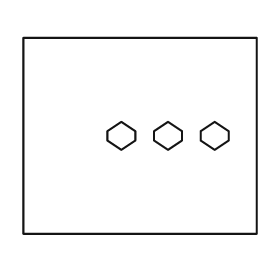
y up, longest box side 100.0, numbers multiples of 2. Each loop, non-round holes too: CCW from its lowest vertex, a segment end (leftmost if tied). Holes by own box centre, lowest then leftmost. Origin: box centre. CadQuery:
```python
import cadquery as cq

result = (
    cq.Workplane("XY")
    .moveTo(-50.0, -42.0)
    .lineTo(50.0, -42.0)
    .lineTo(50.0, 42.0)
    .lineTo(-50.0, 42.0)
    .close()
    .moveTo(-8.0, -6.0)
    .lineTo(-2.0, -2.0)
    .lineTo(-2.0, 2.0)
    .lineTo(-8.0, 6.0)
    .lineTo(-14.0, 2.0)
    .lineTo(-14.0, -2.0)
    .close()
    .moveTo(12.0, -6.0)
    .lineTo(18.0, -2.0)
    .lineTo(18.0, 2.0)
    .lineTo(12.0, 6.0)
    .lineTo(6.0, 2.0)
    .lineTo(6.0, -2.0)
    .close()
    .moveTo(32.0, -6.0)
    .lineTo(38.0, -2.0)
    .lineTo(38.0, 2.0)
    .lineTo(32.0, 6.0)
    .lineTo(26.0, 2.0)
    .lineTo(26.0, -2.0)
    .close()
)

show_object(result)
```